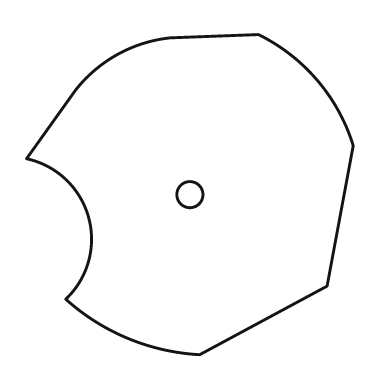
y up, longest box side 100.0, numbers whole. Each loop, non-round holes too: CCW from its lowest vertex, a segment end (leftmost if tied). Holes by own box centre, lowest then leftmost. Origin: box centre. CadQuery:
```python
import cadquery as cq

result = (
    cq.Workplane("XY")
    .moveTo(3.0, -49.0)
    .lineTo(42.0, -28.0)
    .lineTo(50.0, 15.0)
    .threePointArc((39.0, 35.0), (21.0, 49.0))
    .lineTo(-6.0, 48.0)
    .threePointArc((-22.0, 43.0), (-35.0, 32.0))
    .lineTo(-50.0, 11.0)
    .threePointArc((-31.0, -7.0), (-38.0, -32.0))
    .threePointArc((-19.0, -44.0), (3.0, -49.0))
    .close()
    .moveTo(0.0, 0.0)
    .circle(4.0)
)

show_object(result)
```